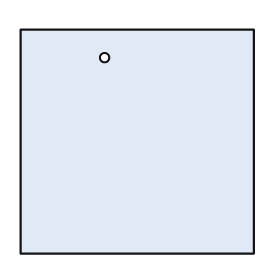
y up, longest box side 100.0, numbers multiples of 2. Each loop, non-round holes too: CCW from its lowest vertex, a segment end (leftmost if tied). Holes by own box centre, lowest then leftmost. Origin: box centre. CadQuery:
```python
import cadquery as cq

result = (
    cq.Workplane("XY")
    .moveTo(-50.0, -48.0)
    .lineTo(50.0, -48.0)
    .lineTo(50.0, 48.0)
    .lineTo(-50.0, 48.0)
    .close()
    .moveTo(-14.0, 36.0)
    .circle(2.0)
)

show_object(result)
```